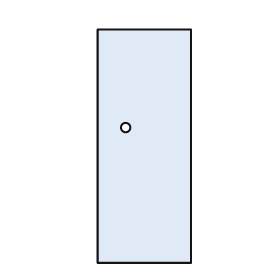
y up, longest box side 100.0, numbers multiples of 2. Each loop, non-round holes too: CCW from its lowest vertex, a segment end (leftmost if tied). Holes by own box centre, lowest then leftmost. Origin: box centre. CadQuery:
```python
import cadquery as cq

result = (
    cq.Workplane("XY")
    .moveTo(-20.0, -50.0)
    .lineTo(20.0, -50.0)
    .lineTo(20.0, 50.0)
    .lineTo(-20.0, 50.0)
    .close()
    .moveTo(-8.0, 8.0)
    .circle(2.0)
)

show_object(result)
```